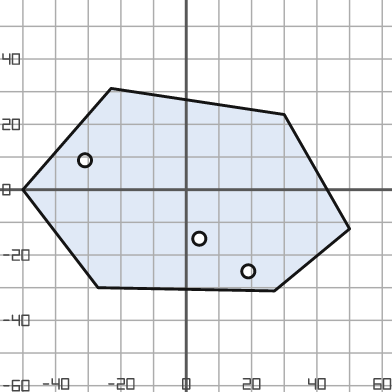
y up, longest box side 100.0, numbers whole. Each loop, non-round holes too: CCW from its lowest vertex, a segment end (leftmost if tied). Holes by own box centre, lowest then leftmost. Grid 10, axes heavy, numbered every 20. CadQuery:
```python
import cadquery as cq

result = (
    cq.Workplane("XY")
    .moveTo(27.0, -31.0)
    .lineTo(50.0, -12.0)
    .lineTo(30.0, 23.0)
    .lineTo(-23.0, 31.0)
    .lineTo(-50.0, 0.0)
    .lineTo(-27.0, -30.0)
    .close()
    .moveTo(19.0, -25.0)
    .circle(2.0)
    .moveTo(4.0, -15.0)
    .circle(2.0)
    .moveTo(-31.0, 9.0)
    .circle(2.0)
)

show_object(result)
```